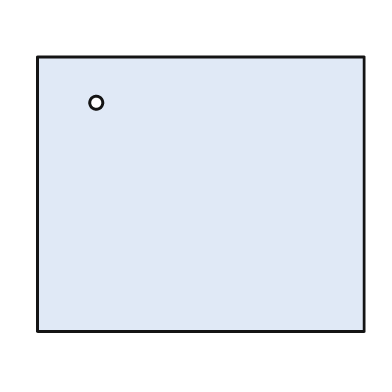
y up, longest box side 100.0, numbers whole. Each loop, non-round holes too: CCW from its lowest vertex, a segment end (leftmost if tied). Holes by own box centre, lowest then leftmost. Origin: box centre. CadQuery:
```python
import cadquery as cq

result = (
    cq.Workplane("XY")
    .moveTo(-50.0, -42.0)
    .lineTo(50.0, -42.0)
    .lineTo(50.0, 42.0)
    .lineTo(-50.0, 42.0)
    .close()
    .moveTo(-32.0, 28.0)
    .circle(2.0)
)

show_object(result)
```